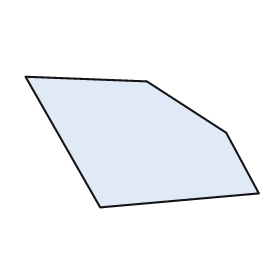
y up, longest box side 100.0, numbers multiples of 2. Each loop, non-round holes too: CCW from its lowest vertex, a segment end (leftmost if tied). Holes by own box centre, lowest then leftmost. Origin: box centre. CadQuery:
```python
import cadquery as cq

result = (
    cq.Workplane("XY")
    .moveTo(-18.0, -28.0)
    .lineTo(50.0, -22.0)
    .lineTo(36.0, 4.0)
    .lineTo(2.0, 26.0)
    .lineTo(-50.0, 28.0)
    .close()
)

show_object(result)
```